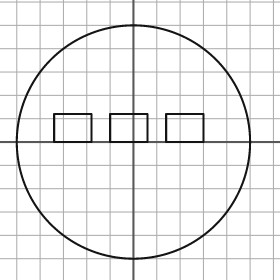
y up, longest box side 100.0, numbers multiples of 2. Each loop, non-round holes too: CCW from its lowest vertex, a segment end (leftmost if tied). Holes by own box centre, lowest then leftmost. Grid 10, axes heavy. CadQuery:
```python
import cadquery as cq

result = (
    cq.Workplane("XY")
    .moveTo(0.0, 0.0)
    .circle(50.0)
    .moveTo(-34.0, 0.0)
    .lineTo(-18.0, 0.0)
    .lineTo(-18.0, 12.0)
    .lineTo(-34.0, 12.0)
    .close()
    .moveTo(-10.0, 0.0)
    .lineTo(6.0, 0.0)
    .lineTo(6.0, 12.0)
    .lineTo(-10.0, 12.0)
    .close()
    .moveTo(14.0, 0.0)
    .lineTo(30.0, 0.0)
    .lineTo(30.0, 12.0)
    .lineTo(14.0, 12.0)
    .close()
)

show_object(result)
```